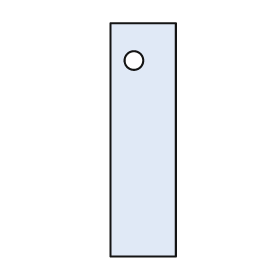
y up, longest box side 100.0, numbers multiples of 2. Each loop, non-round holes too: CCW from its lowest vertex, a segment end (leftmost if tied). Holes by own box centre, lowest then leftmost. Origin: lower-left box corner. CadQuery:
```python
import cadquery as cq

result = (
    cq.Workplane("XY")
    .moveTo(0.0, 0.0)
    .lineTo(28.0, 0.0)
    .lineTo(28.0, 100.0)
    .lineTo(0.0, 100.0)
    .close()
    .moveTo(10.0, 84.0)
    .circle(4.0)
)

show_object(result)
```